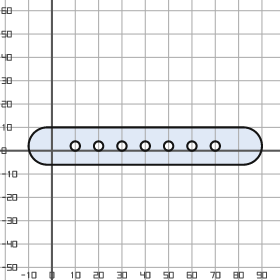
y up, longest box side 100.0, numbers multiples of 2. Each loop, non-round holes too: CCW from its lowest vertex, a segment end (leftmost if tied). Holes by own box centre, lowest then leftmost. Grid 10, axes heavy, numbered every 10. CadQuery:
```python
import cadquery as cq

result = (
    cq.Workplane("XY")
    .moveTo(-2.0, -6.0)
    .lineTo(82.0, -6.0)
    .threePointArc((90.0, 2.0), (82.0, 10.0))
    .lineTo(-2.0, 10.0)
    .threePointArc((-10.0, 2.0), (-2.0, -6.0))
    .close()
    .moveTo(10.0, 2.0)
    .circle(2.0)
    .moveTo(20.0, 2.0)
    .circle(2.0)
    .moveTo(30.0, 2.0)
    .circle(2.0)
    .moveTo(40.0, 2.0)
    .circle(2.0)
    .moveTo(50.0, 2.0)
    .circle(2.0)
    .moveTo(60.0, 2.0)
    .circle(2.0)
    .moveTo(70.0, 2.0)
    .circle(2.0)
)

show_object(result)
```